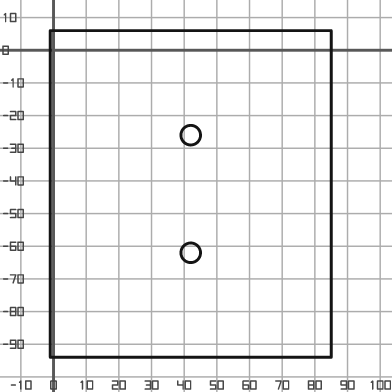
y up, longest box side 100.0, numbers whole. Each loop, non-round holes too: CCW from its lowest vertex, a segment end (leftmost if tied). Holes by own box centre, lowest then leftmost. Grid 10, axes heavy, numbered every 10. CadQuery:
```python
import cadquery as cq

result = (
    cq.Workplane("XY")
    .moveTo(-1.0, -94.0)
    .lineTo(85.0, -94.0)
    .lineTo(85.0, 6.0)
    .lineTo(-1.0, 6.0)
    .close()
    .moveTo(42.0, -62.0)
    .circle(3.0)
    .moveTo(42.0, -26.0)
    .circle(3.0)
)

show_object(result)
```